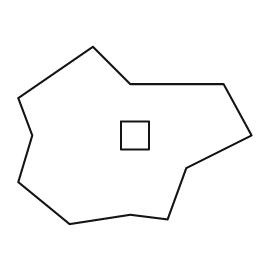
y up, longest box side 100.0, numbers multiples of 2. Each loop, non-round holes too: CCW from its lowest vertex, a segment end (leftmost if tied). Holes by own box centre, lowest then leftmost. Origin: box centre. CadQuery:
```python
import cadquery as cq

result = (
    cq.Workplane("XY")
    .moveTo(-28.0, -38.0)
    .lineTo(-2.0, -34.0)
    .lineTo(14.0, -36.0)
    .lineTo(22.0, -14.0)
    .lineTo(50.0, 0.0)
    .lineTo(38.0, 22.0)
    .lineTo(-2.0, 22.0)
    .lineTo(-18.0, 38.0)
    .lineTo(-50.0, 16.0)
    .lineTo(-44.0, 0.0)
    .lineTo(-50.0, -20.0)
    .close()
    .moveTo(-6.0, -6.0)
    .lineTo(6.0, -6.0)
    .lineTo(6.0, 6.0)
    .lineTo(-6.0, 6.0)
    .close()
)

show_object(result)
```